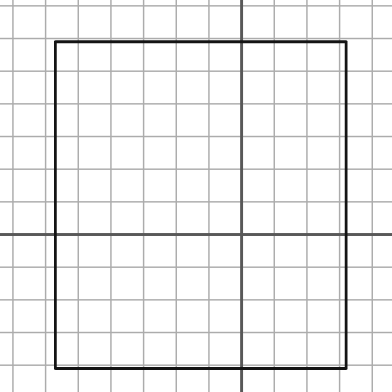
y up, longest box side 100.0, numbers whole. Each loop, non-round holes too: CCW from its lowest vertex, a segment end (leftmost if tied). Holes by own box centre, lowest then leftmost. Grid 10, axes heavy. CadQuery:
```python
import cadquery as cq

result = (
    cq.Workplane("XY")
    .moveTo(-57.0, -41.0)
    .lineTo(32.0, -41.0)
    .lineTo(32.0, 59.0)
    .lineTo(-57.0, 59.0)
    .close()
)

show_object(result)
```